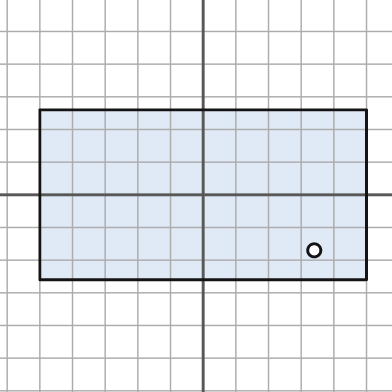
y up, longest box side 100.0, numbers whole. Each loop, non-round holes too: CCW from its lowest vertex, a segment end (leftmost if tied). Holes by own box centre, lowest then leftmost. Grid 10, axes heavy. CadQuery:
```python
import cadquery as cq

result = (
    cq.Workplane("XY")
    .moveTo(-50.0, -26.0)
    .lineTo(50.0, -26.0)
    .lineTo(50.0, 26.0)
    .lineTo(-50.0, 26.0)
    .close()
    .moveTo(34.0, -17.0)
    .circle(2.0)
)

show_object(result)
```